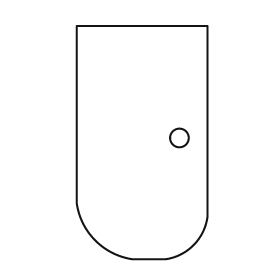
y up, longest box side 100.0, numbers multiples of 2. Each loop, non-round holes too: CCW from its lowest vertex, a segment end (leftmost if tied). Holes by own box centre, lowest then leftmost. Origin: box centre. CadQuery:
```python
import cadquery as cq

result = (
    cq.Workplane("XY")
    .moveTo(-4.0, -50.0)
    .lineTo(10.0, -50.0)
    .threePointArc((22.0, -44.0), (28.0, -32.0))
    .lineTo(28.0, 50.0)
    .lineTo(-28.0, 50.0)
    .lineTo(-28.0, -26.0)
    .threePointArc((-20.0, -42.0), (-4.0, -50.0))
    .close()
    .moveTo(16.0, 2.0)
    .circle(4.0)
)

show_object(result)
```